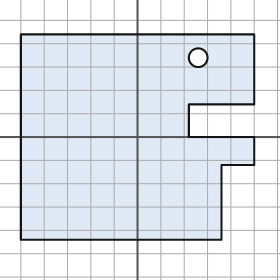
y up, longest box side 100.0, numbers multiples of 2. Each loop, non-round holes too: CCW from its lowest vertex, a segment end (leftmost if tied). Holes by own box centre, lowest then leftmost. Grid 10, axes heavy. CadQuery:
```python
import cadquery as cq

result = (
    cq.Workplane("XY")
    .moveTo(-50.0, -44.0)
    .lineTo(36.0, -44.0)
    .lineTo(36.0, -12.0)
    .lineTo(50.0, -12.0)
    .lineTo(50.0, 0.0)
    .lineTo(22.0, 0.0)
    .lineTo(22.0, 14.0)
    .lineTo(50.0, 14.0)
    .lineTo(50.0, 44.0)
    .lineTo(-50.0, 44.0)
    .close()
    .moveTo(26.0, 34.0)
    .circle(4.0)
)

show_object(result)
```